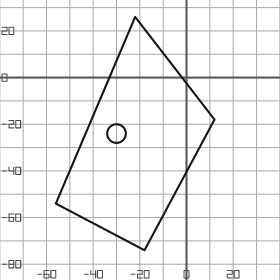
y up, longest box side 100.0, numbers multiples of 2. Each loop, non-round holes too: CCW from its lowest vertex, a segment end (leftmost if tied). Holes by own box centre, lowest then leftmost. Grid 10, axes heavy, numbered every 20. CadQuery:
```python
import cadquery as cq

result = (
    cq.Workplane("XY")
    .moveTo(-18.0, -74.0)
    .lineTo(12.0, -18.0)
    .lineTo(-22.0, 26.0)
    .lineTo(-56.0, -54.0)
    .close()
    .moveTo(-30.0, -24.0)
    .circle(4.0)
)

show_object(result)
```